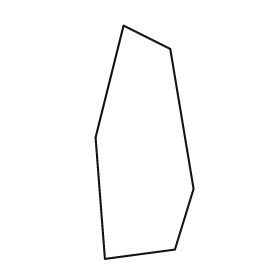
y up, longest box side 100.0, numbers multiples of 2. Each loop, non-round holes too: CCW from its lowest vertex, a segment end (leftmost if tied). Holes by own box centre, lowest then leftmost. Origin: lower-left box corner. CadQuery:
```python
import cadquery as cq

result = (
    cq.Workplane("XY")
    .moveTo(4.0, 0.0)
    .lineTo(34.0, 4.0)
    .lineTo(42.0, 30.0)
    .lineTo(32.0, 90.0)
    .lineTo(12.0, 100.0)
    .lineTo(0.0, 52.0)
    .close()
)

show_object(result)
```